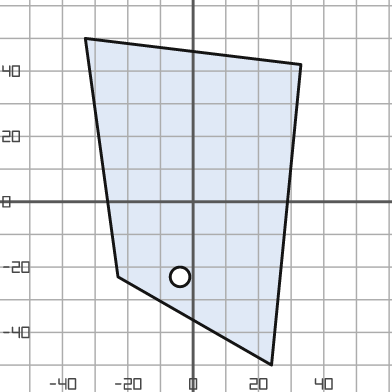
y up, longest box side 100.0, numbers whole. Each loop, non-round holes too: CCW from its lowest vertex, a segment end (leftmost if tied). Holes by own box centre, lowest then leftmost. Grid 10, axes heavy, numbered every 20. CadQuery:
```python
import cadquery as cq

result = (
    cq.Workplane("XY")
    .moveTo(24.0, -50.0)
    .lineTo(33.0, 42.0)
    .lineTo(-33.0, 50.0)
    .lineTo(-23.0, -23.0)
    .close()
    .moveTo(-4.0, -23.0)
    .circle(3.0)
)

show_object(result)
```